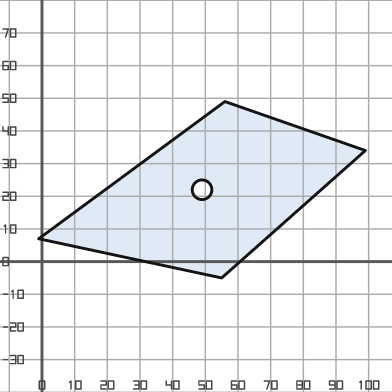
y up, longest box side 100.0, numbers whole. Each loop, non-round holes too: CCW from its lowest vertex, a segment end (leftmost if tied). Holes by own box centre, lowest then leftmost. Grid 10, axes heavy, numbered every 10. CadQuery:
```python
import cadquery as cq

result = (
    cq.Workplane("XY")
    .moveTo(55.0, -5.0)
    .lineTo(99.0, 34.0)
    .lineTo(56.0, 49.0)
    .lineTo(-1.0, 7.0)
    .close()
    .moveTo(49.0, 22.0)
    .circle(3.0)
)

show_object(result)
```